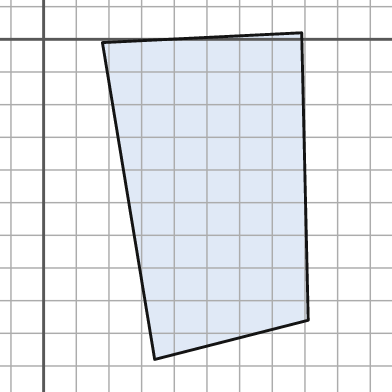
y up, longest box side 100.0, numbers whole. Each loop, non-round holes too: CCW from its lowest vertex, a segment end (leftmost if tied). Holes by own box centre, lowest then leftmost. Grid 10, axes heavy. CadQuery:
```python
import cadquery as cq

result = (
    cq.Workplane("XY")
    .moveTo(34.0, -98.0)
    .lineTo(81.0, -86.0)
    .lineTo(79.0, 2.0)
    .lineTo(18.0, -1.0)
    .close()
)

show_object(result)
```